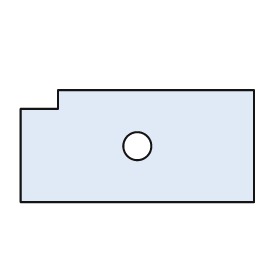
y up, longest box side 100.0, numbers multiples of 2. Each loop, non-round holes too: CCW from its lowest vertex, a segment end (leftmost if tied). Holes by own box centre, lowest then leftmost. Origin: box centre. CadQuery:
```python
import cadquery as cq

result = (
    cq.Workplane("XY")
    .moveTo(-50.0, -24.0)
    .lineTo(50.0, -24.0)
    .lineTo(50.0, 24.0)
    .lineTo(-34.0, 24.0)
    .lineTo(-34.0, 16.0)
    .lineTo(-50.0, 16.0)
    .close()
    .moveTo(0.0, 0.0)
    .circle(6.0)
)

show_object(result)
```